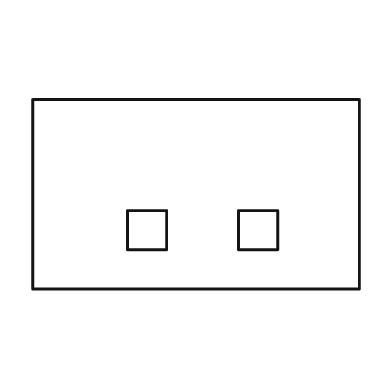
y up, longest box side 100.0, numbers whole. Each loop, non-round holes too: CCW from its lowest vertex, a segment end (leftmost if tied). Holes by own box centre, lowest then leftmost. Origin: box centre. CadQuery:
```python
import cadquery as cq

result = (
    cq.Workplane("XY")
    .moveTo(-50.0, -29.0)
    .lineTo(50.0, -29.0)
    .lineTo(50.0, 29.0)
    .lineTo(-50.0, 29.0)
    .close()
    .moveTo(-21.0, -17.0)
    .lineTo(-9.0, -17.0)
    .lineTo(-9.0, -5.0)
    .lineTo(-21.0, -5.0)
    .close()
    .moveTo(13.0, -17.0)
    .lineTo(25.0, -17.0)
    .lineTo(25.0, -5.0)
    .lineTo(13.0, -5.0)
    .close()
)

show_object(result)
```